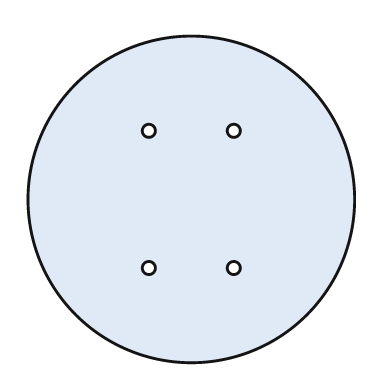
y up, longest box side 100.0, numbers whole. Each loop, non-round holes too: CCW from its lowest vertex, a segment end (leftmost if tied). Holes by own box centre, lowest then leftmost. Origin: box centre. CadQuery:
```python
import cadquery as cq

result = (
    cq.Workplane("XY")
    .moveTo(0.0, 0.0)
    .circle(50.0)
    .moveTo(-13.0, -21.0)
    .circle(2.0)
    .moveTo(13.0, -21.0)
    .circle(2.0)
    .moveTo(-13.0, 21.0)
    .circle(2.0)
    .moveTo(13.0, 21.0)
    .circle(2.0)
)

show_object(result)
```